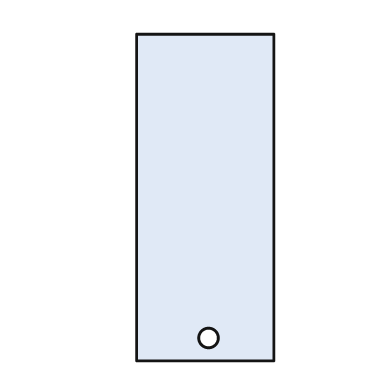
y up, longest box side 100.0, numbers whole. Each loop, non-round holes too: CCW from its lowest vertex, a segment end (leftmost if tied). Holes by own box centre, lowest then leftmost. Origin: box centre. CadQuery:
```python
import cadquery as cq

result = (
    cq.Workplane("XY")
    .moveTo(-21.0, -50.0)
    .lineTo(21.0, -50.0)
    .lineTo(21.0, 50.0)
    .lineTo(-21.0, 50.0)
    .close()
    .moveTo(1.0, -43.0)
    .circle(3.0)
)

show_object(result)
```